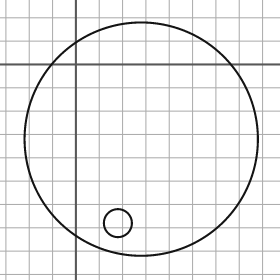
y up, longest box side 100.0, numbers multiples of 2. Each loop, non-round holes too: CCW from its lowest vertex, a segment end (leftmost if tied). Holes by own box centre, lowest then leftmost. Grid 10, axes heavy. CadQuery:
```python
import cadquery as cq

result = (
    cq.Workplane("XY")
    .moveTo(28.0, -32.0)
    .circle(50.0)
    .moveTo(18.0, -68.0)
    .circle(6.0)
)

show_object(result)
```